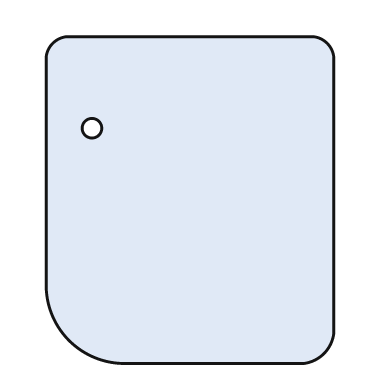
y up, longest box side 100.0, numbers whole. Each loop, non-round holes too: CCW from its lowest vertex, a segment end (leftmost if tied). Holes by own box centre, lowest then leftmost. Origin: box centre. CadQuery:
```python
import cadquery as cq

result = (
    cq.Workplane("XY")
    .moveTo(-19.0, -50.0)
    .lineTo(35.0, -50.0)
    .threePointArc((41.0, -47.0), (44.0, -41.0))
    .lineTo(44.0, 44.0)
    .threePointArc((42.0, 48.0), (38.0, 50.0))
    .lineTo(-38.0, 50.0)
    .threePointArc((-42.0, 48.0), (-44.0, 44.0))
    .lineTo(-44.0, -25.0)
    .threePointArc((-37.0, -43.0), (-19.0, -50.0))
    .close()
    .moveTo(-30.0, 22.0)
    .circle(3.0)
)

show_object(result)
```